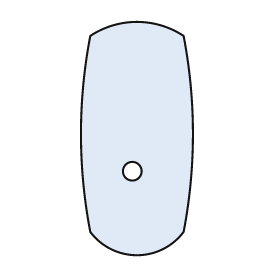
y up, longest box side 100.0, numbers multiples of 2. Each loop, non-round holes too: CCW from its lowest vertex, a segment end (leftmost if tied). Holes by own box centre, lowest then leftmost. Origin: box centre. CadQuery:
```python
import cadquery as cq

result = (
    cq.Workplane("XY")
    .moveTo(-20.0, -40.0)
    .threePointArc((0.0, -50.0), (20.0, -40.0))
    .threePointArc((24.0, 2.0), (20.0, 44.0))
    .threePointArc((0.0, 50.0), (-20.0, 44.0))
    .threePointArc((-24.0, 2.0), (-20.0, -40.0))
    .close()
    .moveTo(-2.0, -14.0)
    .circle(4.0)
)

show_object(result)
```